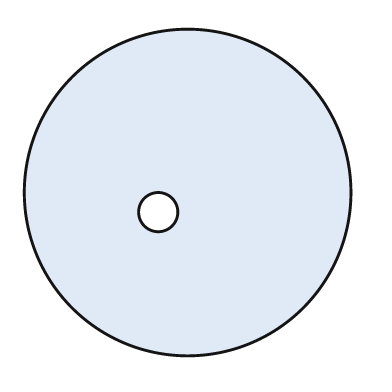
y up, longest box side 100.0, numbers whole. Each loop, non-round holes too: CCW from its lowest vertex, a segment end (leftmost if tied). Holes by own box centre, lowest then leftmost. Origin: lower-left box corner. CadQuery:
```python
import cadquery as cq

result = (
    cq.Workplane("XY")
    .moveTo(50.0, 50.0)
    .circle(50.0)
    .moveTo(41.0, 44.0)
    .circle(6.0)
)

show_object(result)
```